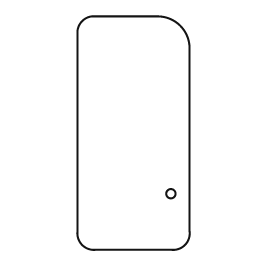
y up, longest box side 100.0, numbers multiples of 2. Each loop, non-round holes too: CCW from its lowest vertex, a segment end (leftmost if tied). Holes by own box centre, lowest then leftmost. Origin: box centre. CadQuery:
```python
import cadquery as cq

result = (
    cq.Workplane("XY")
    .moveTo(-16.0, -50.0)
    .lineTo(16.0, -50.0)
    .threePointArc((22.0, -48.0), (24.0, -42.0))
    .lineTo(24.0, 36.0)
    .threePointArc((20.0, 46.0), (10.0, 50.0))
    .lineTo(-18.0, 50.0)
    .threePointArc((-22.0, 48.0), (-24.0, 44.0))
    .lineTo(-24.0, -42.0)
    .threePointArc((-22.0, -48.0), (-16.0, -50.0))
    .close()
    .moveTo(16.0, -26.0)
    .circle(2.0)
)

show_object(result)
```